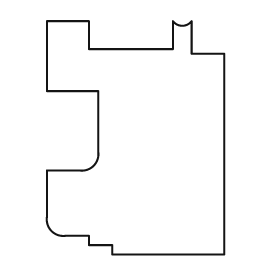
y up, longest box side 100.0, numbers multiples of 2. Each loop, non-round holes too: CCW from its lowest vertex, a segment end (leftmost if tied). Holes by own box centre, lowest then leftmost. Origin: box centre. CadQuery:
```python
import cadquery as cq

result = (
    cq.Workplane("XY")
    .moveTo(-10.0, -50.0)
    .lineTo(38.0, -50.0)
    .lineTo(38.0, 36.0)
    .lineTo(24.0, 36.0)
    .lineTo(24.0, 50.0)
    .threePointArc((20.0, 48.0), (16.0, 50.0))
    .lineTo(16.0, 38.0)
    .lineTo(-20.0, 38.0)
    .lineTo(-20.0, 50.0)
    .lineTo(-38.0, 50.0)
    .lineTo(-38.0, 20.0)
    .lineTo(-16.0, 20.0)
    .lineTo(-16.0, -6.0)
    .threePointArc((-18.0, -12.0), (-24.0, -14.0))
    .lineTo(-38.0, -14.0)
    .lineTo(-38.0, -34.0)
    .threePointArc((-36.0, -40.0), (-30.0, -42.0))
    .lineTo(-20.0, -42.0)
    .lineTo(-20.0, -46.0)
    .lineTo(-10.0, -46.0)
    .close()
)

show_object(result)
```